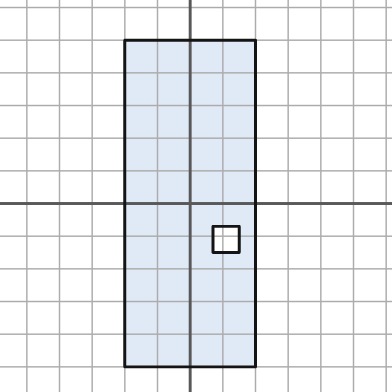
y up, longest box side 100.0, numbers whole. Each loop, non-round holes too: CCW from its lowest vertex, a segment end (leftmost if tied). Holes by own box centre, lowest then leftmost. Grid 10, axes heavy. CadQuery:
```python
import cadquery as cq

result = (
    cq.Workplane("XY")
    .moveTo(-20.0, -50.0)
    .lineTo(20.0, -50.0)
    .lineTo(20.0, 50.0)
    .lineTo(-20.0, 50.0)
    .close()
    .moveTo(7.0, -15.0)
    .lineTo(15.0, -15.0)
    .lineTo(15.0, -7.0)
    .lineTo(7.0, -7.0)
    .close()
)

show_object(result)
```